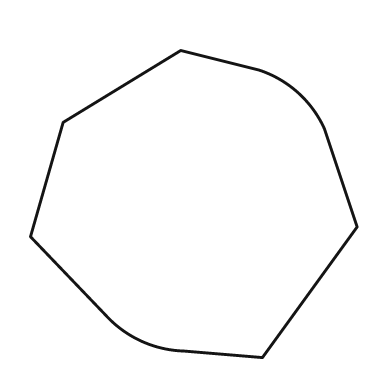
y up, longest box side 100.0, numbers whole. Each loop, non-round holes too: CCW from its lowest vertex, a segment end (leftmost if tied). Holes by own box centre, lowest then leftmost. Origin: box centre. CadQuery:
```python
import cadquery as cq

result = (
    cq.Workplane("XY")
    .moveTo(21.0, -47.0)
    .lineTo(50.0, -7.0)
    .lineTo(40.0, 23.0)
    .threePointArc((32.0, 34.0), (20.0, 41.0))
    .lineTo(-4.0, 47.0)
    .lineTo(-40.0, 25.0)
    .lineTo(-50.0, -10.0)
    .lineTo(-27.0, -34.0)
    .threePointArc((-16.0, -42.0), (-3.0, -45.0))
    .close()
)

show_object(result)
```